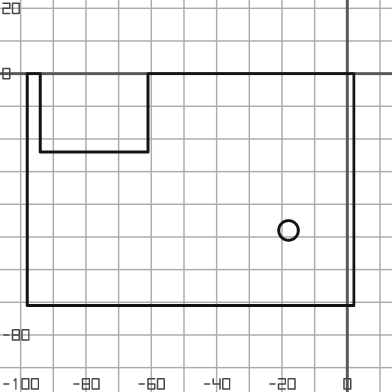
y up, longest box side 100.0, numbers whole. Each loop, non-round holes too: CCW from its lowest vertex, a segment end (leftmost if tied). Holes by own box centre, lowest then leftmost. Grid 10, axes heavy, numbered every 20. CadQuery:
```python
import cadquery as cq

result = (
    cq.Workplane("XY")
    .moveTo(-98.0, -71.0)
    .lineTo(2.0, -71.0)
    .lineTo(2.0, 0.0)
    .lineTo(-61.0, 0.0)
    .lineTo(-61.0, -24.0)
    .lineTo(-94.0, -24.0)
    .lineTo(-94.0, 0.0)
    .lineTo(-98.0, 0.0)
    .close()
    .moveTo(-18.0, -48.0)
    .circle(3.0)
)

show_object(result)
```